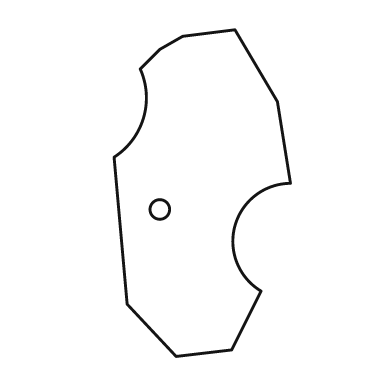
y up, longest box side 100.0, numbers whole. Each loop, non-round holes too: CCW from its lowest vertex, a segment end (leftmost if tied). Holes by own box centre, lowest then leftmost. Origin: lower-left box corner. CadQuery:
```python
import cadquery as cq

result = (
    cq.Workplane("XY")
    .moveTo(19.0, 0.0)
    .lineTo(36.0, 2.0)
    .lineTo(45.0, 20.0)
    .threePointArc((37.0, 40.0), (54.0, 53.0))
    .lineTo(50.0, 78.0)
    .lineTo(37.0, 100.0)
    .lineTo(21.0, 98.0)
    .lineTo(14.0, 94.0)
    .lineTo(8.0, 88.0)
    .threePointArc((9.0, 73.0), (0.0, 61.0))
    .lineTo(4.0, 16.0)
    .close()
    .moveTo(14.0, 45.0)
    .circle(3.0)
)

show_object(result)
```